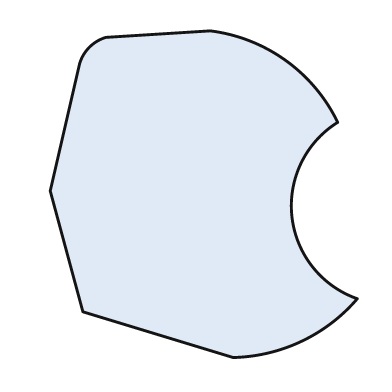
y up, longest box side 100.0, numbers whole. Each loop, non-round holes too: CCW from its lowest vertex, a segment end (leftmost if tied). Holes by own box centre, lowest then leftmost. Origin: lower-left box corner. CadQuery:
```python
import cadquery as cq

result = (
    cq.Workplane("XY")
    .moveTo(56.0, 0.0)
    .threePointArc((77.0, 5.0), (94.0, 18.0))
    .threePointArc((74.0, 43.0), (88.0, 72.0))
    .threePointArc((72.0, 91.0), (49.0, 100.0))
    .lineTo(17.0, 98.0)
    .threePointArc((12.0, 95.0), (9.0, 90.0))
    .lineTo(0.0, 51.0)
    .lineTo(10.0, 14.0)
    .close()
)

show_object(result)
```